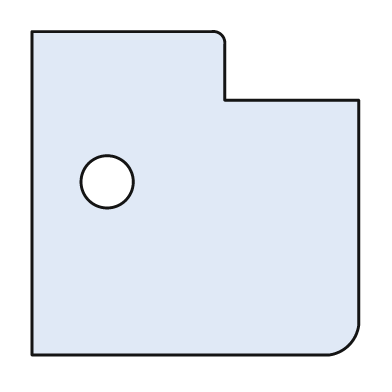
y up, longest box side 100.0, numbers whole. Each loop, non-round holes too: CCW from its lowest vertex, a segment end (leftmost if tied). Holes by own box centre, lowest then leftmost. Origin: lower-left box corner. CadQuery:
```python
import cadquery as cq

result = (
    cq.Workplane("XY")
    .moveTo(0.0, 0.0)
    .lineTo(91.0, 0.0)
    .threePointArc((97.0, 3.0), (100.0, 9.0))
    .lineTo(100.0, 78.0)
    .lineTo(59.0, 78.0)
    .lineTo(59.0, 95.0)
    .threePointArc((58.0, 98.0), (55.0, 99.0))
    .lineTo(0.0, 99.0)
    .close()
    .moveTo(23.0, 53.0)
    .circle(8.0)
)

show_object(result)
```